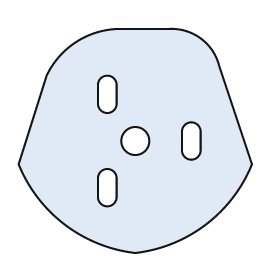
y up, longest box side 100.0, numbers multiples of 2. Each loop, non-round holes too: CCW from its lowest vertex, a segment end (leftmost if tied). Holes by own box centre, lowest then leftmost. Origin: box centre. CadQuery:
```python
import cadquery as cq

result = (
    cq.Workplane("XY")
    .moveTo(0.0, -48.0)
    .threePointArc((30.0, -36.0), (50.0, -10.0))
    .lineTo(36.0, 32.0)
    .threePointArc((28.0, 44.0), (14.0, 48.0))
    .lineTo(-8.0, 48.0)
    .threePointArc((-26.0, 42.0), (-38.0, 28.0))
    .lineTo(-50.0, -10.0)
    .threePointArc((-30.0, -36.0), (0.0, -48.0))
    .close()
    .moveTo(-16.0, -24.0)
    .threePointArc((-12.0, -28.0), (-8.0, -24.0))
    .lineTo(-8.0, -16.0)
    .threePointArc((-12.0, -12.0), (-16.0, -16.0))
    .close()
    .moveTo(0.0, 0.0)
    .circle(6.0)
    .moveTo(20.0, -4.0)
    .threePointArc((24.0, -8.0), (28.0, -4.0))
    .lineTo(28.0, 4.0)
    .threePointArc((24.0, 8.0), (20.0, 4.0))
    .close()
    .moveTo(-16.0, 16.0)
    .threePointArc((-12.0, 12.0), (-8.0, 16.0))
    .lineTo(-8.0, 24.0)
    .threePointArc((-12.0, 28.0), (-16.0, 24.0))
    .close()
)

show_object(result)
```